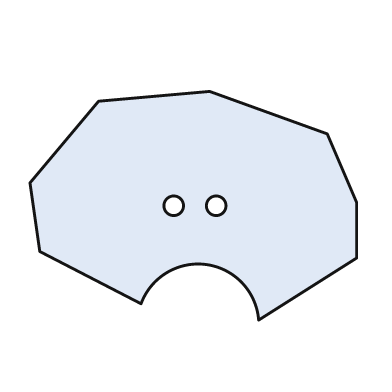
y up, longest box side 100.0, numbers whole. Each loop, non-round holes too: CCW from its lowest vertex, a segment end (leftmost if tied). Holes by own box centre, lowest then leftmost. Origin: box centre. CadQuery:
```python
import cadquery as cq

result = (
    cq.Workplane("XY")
    .moveTo(20.0, -35.0)
    .lineTo(50.0, -16.0)
    .lineTo(50.0, 1.0)
    .lineTo(41.0, 22.0)
    .lineTo(5.0, 35.0)
    .lineTo(-29.0, 32.0)
    .lineTo(-50.0, 7.0)
    .lineTo(-47.0, -14.0)
    .lineTo(-16.0, -30.0)
    .threePointArc((4.0, -18.0), (20.0, -35.0))
    .close()
    .moveTo(-6.0, 0.0)
    .circle(3.0)
    .moveTo(7.0, 0.0)
    .circle(3.0)
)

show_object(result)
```